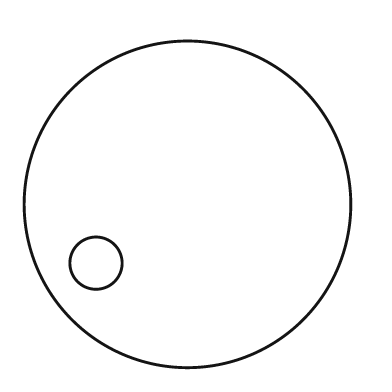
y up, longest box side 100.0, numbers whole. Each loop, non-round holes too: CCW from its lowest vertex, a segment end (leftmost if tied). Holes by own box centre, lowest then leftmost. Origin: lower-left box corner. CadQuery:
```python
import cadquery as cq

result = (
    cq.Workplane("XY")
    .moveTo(50.0, 50.0)
    .circle(50.0)
    .moveTo(22.0, 32.0)
    .circle(8.0)
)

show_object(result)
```